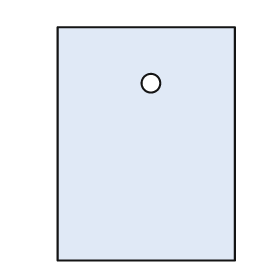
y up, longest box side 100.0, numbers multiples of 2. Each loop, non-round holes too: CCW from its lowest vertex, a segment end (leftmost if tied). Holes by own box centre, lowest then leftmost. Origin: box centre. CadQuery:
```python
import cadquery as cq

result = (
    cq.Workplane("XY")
    .moveTo(-38.0, -50.0)
    .lineTo(38.0, -50.0)
    .lineTo(38.0, 50.0)
    .lineTo(-38.0, 50.0)
    .close()
    .moveTo(2.0, 26.0)
    .circle(4.0)
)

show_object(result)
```